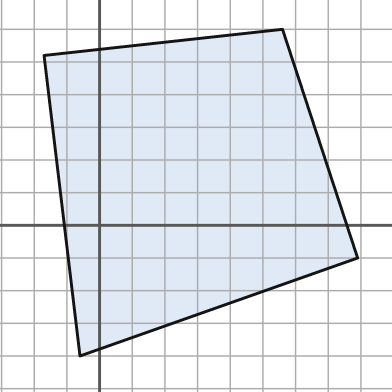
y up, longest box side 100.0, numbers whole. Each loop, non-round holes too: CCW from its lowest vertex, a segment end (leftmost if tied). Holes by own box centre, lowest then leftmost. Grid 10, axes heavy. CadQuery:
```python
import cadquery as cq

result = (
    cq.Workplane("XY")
    .moveTo(-6.0, -40.0)
    .lineTo(79.0, -10.0)
    .lineTo(56.0, 60.0)
    .lineTo(-17.0, 52.0)
    .close()
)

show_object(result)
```